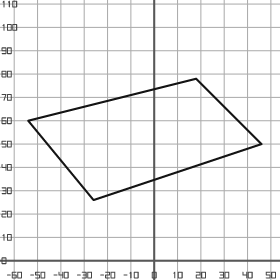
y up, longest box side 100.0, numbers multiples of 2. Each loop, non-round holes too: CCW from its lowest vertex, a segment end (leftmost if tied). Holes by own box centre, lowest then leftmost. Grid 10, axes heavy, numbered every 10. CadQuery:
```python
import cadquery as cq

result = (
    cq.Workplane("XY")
    .moveTo(-26.0, 26.0)
    .lineTo(46.0, 50.0)
    .lineTo(18.0, 78.0)
    .lineTo(-54.0, 60.0)
    .close()
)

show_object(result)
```